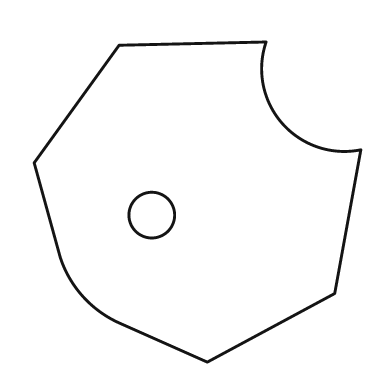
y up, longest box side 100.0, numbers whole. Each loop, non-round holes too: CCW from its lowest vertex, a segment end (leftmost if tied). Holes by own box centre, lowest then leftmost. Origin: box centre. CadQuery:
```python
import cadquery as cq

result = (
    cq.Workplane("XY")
    .moveTo(3.0, -49.0)
    .lineTo(42.0, -28.0)
    .lineTo(50.0, 16.0)
    .threePointArc((26.0, 24.0), (21.0, 49.0))
    .lineTo(-24.0, 48.0)
    .lineTo(-50.0, 12.0)
    .lineTo(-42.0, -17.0)
    .threePointArc((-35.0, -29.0), (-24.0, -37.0))
    .close()
    .moveTo(-14.0, -4.0)
    .circle(7.0)
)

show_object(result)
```